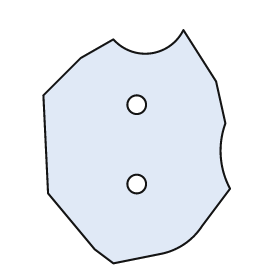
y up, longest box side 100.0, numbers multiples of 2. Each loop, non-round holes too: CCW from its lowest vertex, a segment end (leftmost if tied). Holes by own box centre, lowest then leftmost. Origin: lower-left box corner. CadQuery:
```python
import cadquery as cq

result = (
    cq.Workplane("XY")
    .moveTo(30.0, 0.0)
    .lineTo(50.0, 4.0)
    .threePointArc((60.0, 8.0), (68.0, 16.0))
    .lineTo(80.0, 32.0)
    .threePointArc((76.0, 46.0), (78.0, 60.0))
    .lineTo(74.0, 78.0)
    .lineTo(60.0, 100.0)
    .threePointArc((46.0, 90.0), (30.0, 96.0))
    .lineTo(16.0, 88.0)
    .lineTo(0.0, 72.0)
    .lineTo(2.0, 30.0)
    .lineTo(22.0, 6.0)
    .close()
    .moveTo(40.0, 34.0)
    .circle(4.0)
    .moveTo(40.0, 68.0)
    .circle(4.0)
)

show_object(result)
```